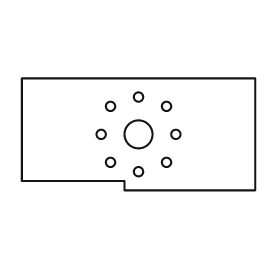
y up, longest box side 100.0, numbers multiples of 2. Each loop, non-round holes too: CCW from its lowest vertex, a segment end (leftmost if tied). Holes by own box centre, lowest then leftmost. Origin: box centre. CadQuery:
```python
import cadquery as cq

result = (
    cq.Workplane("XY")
    .moveTo(-6.0, -24.0)
    .lineTo(50.0, -24.0)
    .lineTo(50.0, 24.0)
    .lineTo(-50.0, 24.0)
    .lineTo(-50.0, -20.0)
    .lineTo(-6.0, -20.0)
    .close()
    .moveTo(0.0, -16.0)
    .circle(2.0)
    .moveTo(-12.0, -12.0)
    .circle(2.0)
    .moveTo(12.0, -12.0)
    .circle(2.0)
    .moveTo(-16.0, 0.0)
    .circle(2.0)
    .moveTo(0.0, 0.0)
    .circle(6.0)
    .moveTo(16.0, 0.0)
    .circle(2.0)
    .moveTo(-12.0, 12.0)
    .circle(2.0)
    .moveTo(12.0, 12.0)
    .circle(2.0)
    .moveTo(0.0, 16.0)
    .circle(2.0)
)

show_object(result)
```